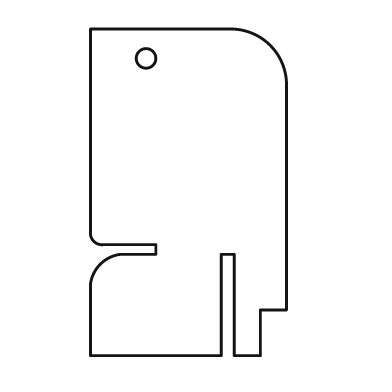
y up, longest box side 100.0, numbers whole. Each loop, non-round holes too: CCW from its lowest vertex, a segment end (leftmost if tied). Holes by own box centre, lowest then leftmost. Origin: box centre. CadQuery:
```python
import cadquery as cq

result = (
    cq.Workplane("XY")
    .moveTo(-30.0, -50.0)
    .lineTo(10.0, -50.0)
    .lineTo(10.0, -19.0)
    .lineTo(14.0, -19.0)
    .lineTo(14.0, -50.0)
    .lineTo(22.0, -50.0)
    .lineTo(22.0, -36.0)
    .lineTo(30.0, -36.0)
    .lineTo(30.0, 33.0)
    .threePointArc((25.0, 45.0), (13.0, 50.0))
    .lineTo(-30.0, 50.0)
    .lineTo(-30.0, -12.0)
    .threePointArc((-29.0, -15.0), (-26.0, -16.0))
    .lineTo(-10.0, -16.0)
    .lineTo(-10.0, -19.0)
    .lineTo(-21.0, -19.0)
    .threePointArc((-27.0, -22.0), (-30.0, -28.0))
    .close()
    .moveTo(-13.0, 41.0)
    .circle(3.0)
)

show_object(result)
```